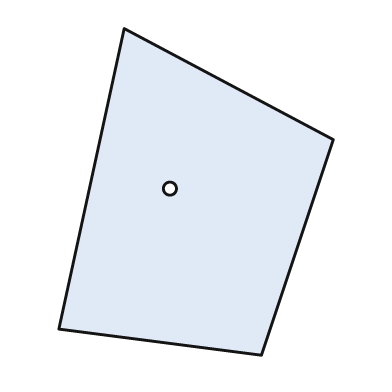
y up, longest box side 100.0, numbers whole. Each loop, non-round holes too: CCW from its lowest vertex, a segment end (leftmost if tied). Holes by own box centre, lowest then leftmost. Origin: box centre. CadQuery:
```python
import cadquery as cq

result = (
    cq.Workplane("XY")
    .moveTo(20.0, -50.0)
    .lineTo(42.0, 16.0)
    .lineTo(-22.0, 50.0)
    .lineTo(-42.0, -42.0)
    .close()
    .moveTo(-8.0, 1.0)
    .circle(2.0)
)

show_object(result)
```